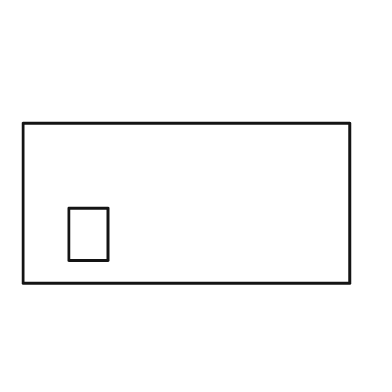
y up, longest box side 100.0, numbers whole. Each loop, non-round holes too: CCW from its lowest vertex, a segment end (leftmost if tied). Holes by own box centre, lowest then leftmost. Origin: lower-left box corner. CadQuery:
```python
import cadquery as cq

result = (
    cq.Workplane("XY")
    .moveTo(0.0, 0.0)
    .lineTo(100.0, 0.0)
    .lineTo(100.0, 49.0)
    .lineTo(0.0, 49.0)
    .close()
    .moveTo(14.0, 7.0)
    .lineTo(26.0, 7.0)
    .lineTo(26.0, 23.0)
    .lineTo(14.0, 23.0)
    .close()
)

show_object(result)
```